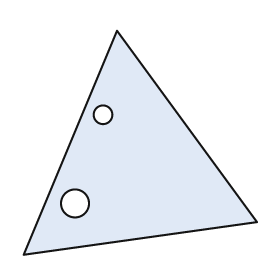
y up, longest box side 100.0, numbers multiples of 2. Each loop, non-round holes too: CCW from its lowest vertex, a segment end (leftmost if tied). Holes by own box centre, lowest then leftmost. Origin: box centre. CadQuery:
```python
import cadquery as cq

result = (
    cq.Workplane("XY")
    .moveTo(-50.0, -48.0)
    .lineTo(50.0, -34.0)
    .lineTo(-10.0, 48.0)
    .close()
    .moveTo(-28.0, -26.0)
    .circle(6.0)
    .moveTo(-16.0, 12.0)
    .circle(4.0)
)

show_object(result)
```